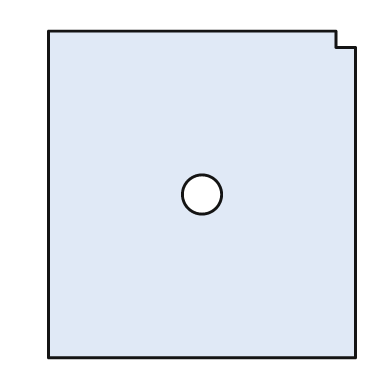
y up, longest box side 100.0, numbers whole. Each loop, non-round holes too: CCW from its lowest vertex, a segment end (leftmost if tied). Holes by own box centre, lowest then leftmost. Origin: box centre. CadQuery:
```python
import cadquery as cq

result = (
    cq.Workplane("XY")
    .moveTo(-47.0, -50.0)
    .lineTo(47.0, -50.0)
    .lineTo(47.0, 45.0)
    .lineTo(41.0, 45.0)
    .lineTo(41.0, 50.0)
    .lineTo(-47.0, 50.0)
    .close()
    .moveTo(0.0, 0.0)
    .circle(6.0)
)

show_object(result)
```